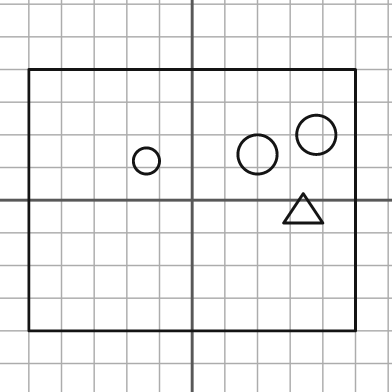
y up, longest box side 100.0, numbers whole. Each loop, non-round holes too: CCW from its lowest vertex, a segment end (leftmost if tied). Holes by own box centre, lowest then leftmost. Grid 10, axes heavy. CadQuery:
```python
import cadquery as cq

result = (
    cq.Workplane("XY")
    .moveTo(-50.0, -40.0)
    .lineTo(50.0, -40.0)
    .lineTo(50.0, 40.0)
    .lineTo(-50.0, 40.0)
    .close()
    .moveTo(28.0, -7.0)
    .lineTo(40.0, -7.0)
    .lineTo(34.0, 2.0)
    .close()
    .moveTo(-14.0, 12.0)
    .circle(4.0)
    .moveTo(20.0, 14.0)
    .circle(6.0)
    .moveTo(38.0, 20.0)
    .circle(6.0)
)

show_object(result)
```